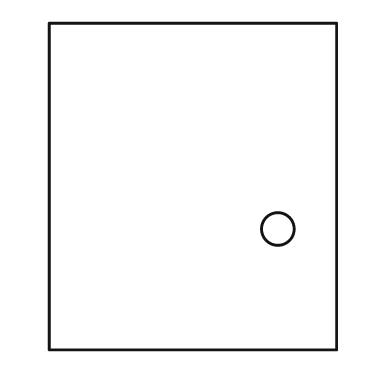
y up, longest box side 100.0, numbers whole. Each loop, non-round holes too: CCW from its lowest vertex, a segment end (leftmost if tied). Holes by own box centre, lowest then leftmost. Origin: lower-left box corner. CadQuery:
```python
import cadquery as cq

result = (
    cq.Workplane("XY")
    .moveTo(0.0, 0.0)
    .lineTo(88.0, 0.0)
    .lineTo(88.0, 100.0)
    .lineTo(0.0, 100.0)
    .close()
    .moveTo(70.0, 37.0)
    .circle(5.0)
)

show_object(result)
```